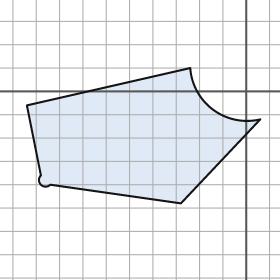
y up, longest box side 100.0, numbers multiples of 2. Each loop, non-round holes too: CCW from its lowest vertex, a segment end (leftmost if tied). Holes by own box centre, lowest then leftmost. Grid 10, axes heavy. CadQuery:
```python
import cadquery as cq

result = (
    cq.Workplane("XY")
    .moveTo(-28.0, -48.0)
    .lineTo(6.0, -12.0)
    .threePointArc((-14.0, -8.0), (-24.0, 10.0))
    .lineTo(-94.0, -6.0)
    .lineTo(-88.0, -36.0)
    .threePointArc((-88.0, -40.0), (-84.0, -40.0))
    .close()
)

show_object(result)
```